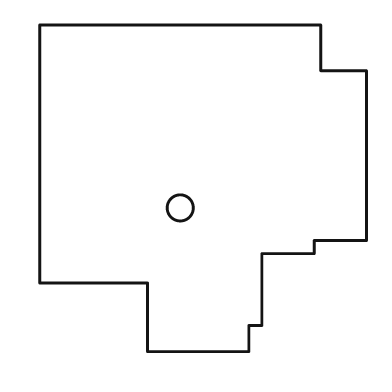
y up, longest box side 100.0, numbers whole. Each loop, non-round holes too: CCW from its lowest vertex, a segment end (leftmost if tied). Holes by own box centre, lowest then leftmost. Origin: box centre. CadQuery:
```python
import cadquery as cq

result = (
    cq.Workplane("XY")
    .moveTo(-17.0, -50.0)
    .lineTo(14.0, -50.0)
    .lineTo(14.0, -42.0)
    .lineTo(18.0, -42.0)
    .lineTo(18.0, -20.0)
    .lineTo(34.0, -20.0)
    .lineTo(34.0, -16.0)
    .lineTo(50.0, -16.0)
    .lineTo(50.0, 36.0)
    .lineTo(36.0, 36.0)
    .lineTo(36.0, 50.0)
    .lineTo(-50.0, 50.0)
    .lineTo(-50.0, -29.0)
    .lineTo(-17.0, -29.0)
    .close()
    .moveTo(-7.0, -6.0)
    .circle(4.0)
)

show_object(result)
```